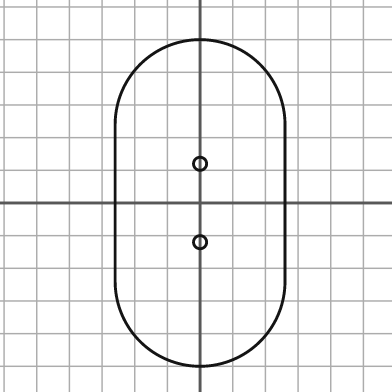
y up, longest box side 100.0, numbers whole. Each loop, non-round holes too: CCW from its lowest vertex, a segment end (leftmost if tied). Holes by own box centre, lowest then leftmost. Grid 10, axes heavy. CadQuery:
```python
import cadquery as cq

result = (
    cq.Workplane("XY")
    .moveTo(-26.0, -24.0)
    .threePointArc((0.0, -50.0), (26.0, -24.0))
    .lineTo(26.0, 24.0)
    .threePointArc((0.0, 50.0), (-26.0, 24.0))
    .close()
    .moveTo(0.0, -12.0)
    .circle(2.0)
    .moveTo(0.0, 12.0)
    .circle(2.0)
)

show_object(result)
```